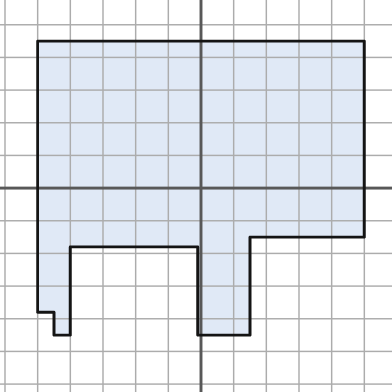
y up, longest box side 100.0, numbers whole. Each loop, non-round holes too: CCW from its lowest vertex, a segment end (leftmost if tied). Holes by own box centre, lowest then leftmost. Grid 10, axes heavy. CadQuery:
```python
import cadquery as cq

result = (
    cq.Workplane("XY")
    .moveTo(-45.0, -45.0)
    .lineTo(-40.0, -45.0)
    .lineTo(-40.0, -18.0)
    .lineTo(-1.0, -18.0)
    .lineTo(-1.0, -45.0)
    .lineTo(15.0, -45.0)
    .lineTo(15.0, -15.0)
    .lineTo(50.0, -15.0)
    .lineTo(50.0, 45.0)
    .lineTo(-50.0, 45.0)
    .lineTo(-50.0, -38.0)
    .lineTo(-45.0, -38.0)
    .close()
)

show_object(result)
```